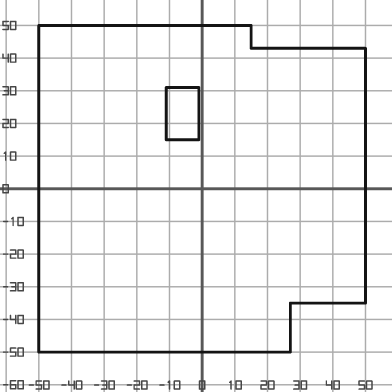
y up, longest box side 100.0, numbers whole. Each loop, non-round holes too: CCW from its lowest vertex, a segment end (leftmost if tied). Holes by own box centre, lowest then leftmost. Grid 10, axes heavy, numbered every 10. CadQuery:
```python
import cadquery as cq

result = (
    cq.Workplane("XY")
    .moveTo(-50.0, -50.0)
    .lineTo(27.0, -50.0)
    .lineTo(27.0, -35.0)
    .lineTo(50.0, -35.0)
    .lineTo(50.0, 43.0)
    .lineTo(15.0, 43.0)
    .lineTo(15.0, 50.0)
    .lineTo(-50.0, 50.0)
    .close()
    .moveTo(-11.0, 15.0)
    .lineTo(-1.0, 15.0)
    .lineTo(-1.0, 31.0)
    .lineTo(-11.0, 31.0)
    .close()
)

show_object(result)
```